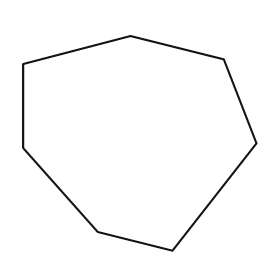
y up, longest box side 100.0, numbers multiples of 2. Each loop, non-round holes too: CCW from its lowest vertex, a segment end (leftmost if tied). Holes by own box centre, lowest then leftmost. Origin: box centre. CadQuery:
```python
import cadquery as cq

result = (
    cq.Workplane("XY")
    .moveTo(14.0, -46.0)
    .lineTo(50.0, 0.0)
    .lineTo(36.0, 36.0)
    .lineTo(-4.0, 46.0)
    .lineTo(-50.0, 34.0)
    .lineTo(-50.0, -2.0)
    .lineTo(-18.0, -38.0)
    .close()
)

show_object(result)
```